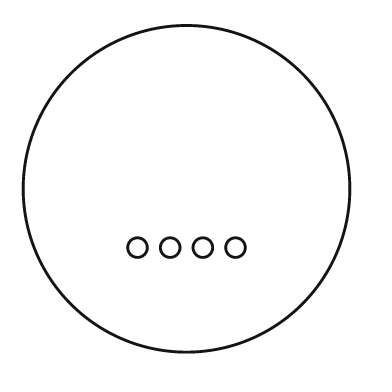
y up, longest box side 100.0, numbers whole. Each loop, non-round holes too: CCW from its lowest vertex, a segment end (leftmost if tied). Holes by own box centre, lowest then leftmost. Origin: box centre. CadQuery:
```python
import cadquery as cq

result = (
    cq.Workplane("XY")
    .moveTo(0.0, 0.0)
    .circle(50.0)
    .moveTo(-15.0, -18.0)
    .circle(3.0)
    .moveTo(-5.0, -18.0)
    .circle(3.0)
    .moveTo(5.0, -18.0)
    .circle(3.0)
    .moveTo(15.0, -18.0)
    .circle(3.0)
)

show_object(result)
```